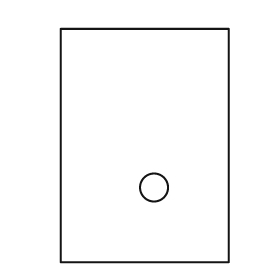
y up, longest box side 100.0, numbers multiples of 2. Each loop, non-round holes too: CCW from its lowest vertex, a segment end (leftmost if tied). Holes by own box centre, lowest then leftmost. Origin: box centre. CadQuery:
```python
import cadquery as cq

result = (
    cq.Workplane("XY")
    .moveTo(-36.0, -50.0)
    .lineTo(36.0, -50.0)
    .lineTo(36.0, 50.0)
    .lineTo(-36.0, 50.0)
    .close()
    .moveTo(4.0, -18.0)
    .circle(6.0)
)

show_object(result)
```